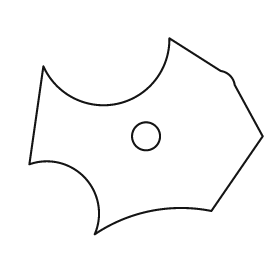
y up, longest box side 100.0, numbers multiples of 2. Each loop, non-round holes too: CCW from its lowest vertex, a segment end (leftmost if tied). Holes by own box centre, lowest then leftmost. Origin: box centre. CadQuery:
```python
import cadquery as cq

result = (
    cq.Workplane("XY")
    .moveTo(-22.0, -42.0)
    .threePointArc((2.0, -32.0), (28.0, -32.0))
    .lineTo(50.0, 0.0)
    .lineTo(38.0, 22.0)
    .threePointArc((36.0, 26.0), (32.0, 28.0))
    .lineTo(10.0, 42.0)
    .threePointArc((-12.0, 14.0), (-44.0, 30.0))
    .lineTo(-50.0, -12.0)
    .threePointArc((-26.0, -18.0), (-22.0, -42.0))
    .close()
    .moveTo(0.0, 0.0)
    .circle(6.0)
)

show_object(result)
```